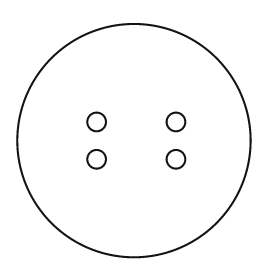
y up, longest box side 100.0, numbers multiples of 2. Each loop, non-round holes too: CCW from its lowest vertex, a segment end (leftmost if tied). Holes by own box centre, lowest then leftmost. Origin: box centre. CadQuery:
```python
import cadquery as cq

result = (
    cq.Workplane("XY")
    .moveTo(0.0, 0.0)
    .circle(50.0)
    .moveTo(-16.0, -8.0)
    .circle(4.0)
    .moveTo(18.0, -8.0)
    .circle(4.0)
    .moveTo(-16.0, 8.0)
    .circle(4.0)
    .moveTo(18.0, 8.0)
    .circle(4.0)
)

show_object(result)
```